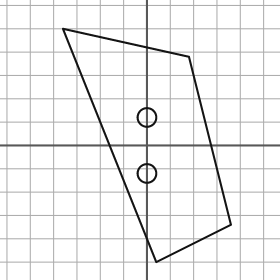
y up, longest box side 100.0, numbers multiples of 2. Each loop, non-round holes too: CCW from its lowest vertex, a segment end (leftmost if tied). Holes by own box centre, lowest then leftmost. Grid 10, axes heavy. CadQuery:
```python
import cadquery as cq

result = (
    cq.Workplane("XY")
    .moveTo(4.0, -50.0)
    .lineTo(36.0, -34.0)
    .lineTo(18.0, 38.0)
    .lineTo(-36.0, 50.0)
    .close()
    .moveTo(0.0, -12.0)
    .circle(4.0)
    .moveTo(0.0, 12.0)
    .circle(4.0)
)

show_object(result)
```